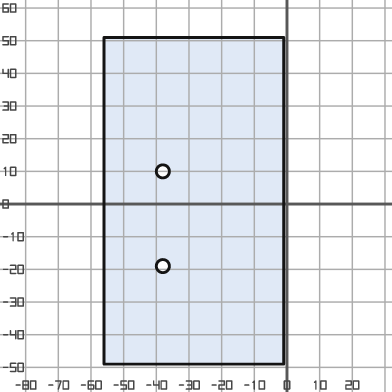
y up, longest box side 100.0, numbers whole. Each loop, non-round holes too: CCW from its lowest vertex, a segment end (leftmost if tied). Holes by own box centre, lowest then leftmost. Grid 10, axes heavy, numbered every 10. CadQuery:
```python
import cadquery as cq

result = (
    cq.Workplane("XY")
    .moveTo(-56.0, -49.0)
    .lineTo(-1.0, -49.0)
    .lineTo(-1.0, 51.0)
    .lineTo(-56.0, 51.0)
    .close()
    .moveTo(-38.0, -19.0)
    .circle(2.0)
    .moveTo(-38.0, 10.0)
    .circle(2.0)
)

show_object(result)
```